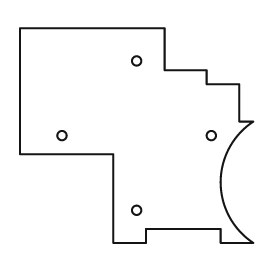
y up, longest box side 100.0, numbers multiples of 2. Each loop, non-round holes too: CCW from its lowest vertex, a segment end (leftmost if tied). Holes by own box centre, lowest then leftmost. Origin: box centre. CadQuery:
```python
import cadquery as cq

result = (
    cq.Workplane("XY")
    .moveTo(-10.0, -46.0)
    .lineTo(4.0, -46.0)
    .lineTo(4.0, -40.0)
    .lineTo(36.0, -40.0)
    .lineTo(36.0, -46.0)
    .lineTo(50.0, -46.0)
    .threePointArc((36.0, -20.0), (50.0, 6.0))
    .lineTo(44.0, 6.0)
    .lineTo(44.0, 22.0)
    .lineTo(30.0, 22.0)
    .lineTo(30.0, 28.0)
    .lineTo(12.0, 28.0)
    .lineTo(12.0, 46.0)
    .lineTo(-50.0, 46.0)
    .lineTo(-50.0, -8.0)
    .lineTo(-10.0, -8.0)
    .close()
    .moveTo(0.0, -32.0)
    .circle(2.0)
    .moveTo(-32.0, 0.0)
    .circle(2.0)
    .moveTo(32.0, 0.0)
    .circle(2.0)
    .moveTo(0.0, 32.0)
    .circle(2.0)
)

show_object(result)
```